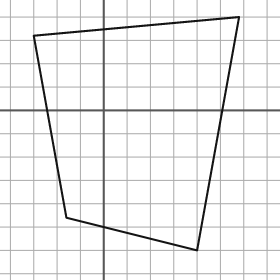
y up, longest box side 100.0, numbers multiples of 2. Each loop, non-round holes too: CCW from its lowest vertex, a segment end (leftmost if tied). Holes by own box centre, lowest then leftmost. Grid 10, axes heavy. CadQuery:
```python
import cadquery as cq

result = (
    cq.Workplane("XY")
    .moveTo(40.0, -60.0)
    .lineTo(58.0, 40.0)
    .lineTo(-30.0, 32.0)
    .lineTo(-16.0, -46.0)
    .close()
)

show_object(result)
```